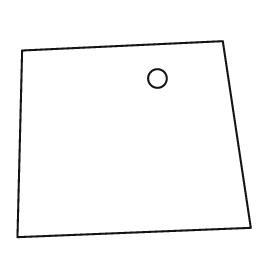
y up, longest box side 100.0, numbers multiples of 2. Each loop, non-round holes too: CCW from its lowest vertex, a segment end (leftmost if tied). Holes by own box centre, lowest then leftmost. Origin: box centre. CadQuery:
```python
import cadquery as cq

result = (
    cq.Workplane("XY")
    .moveTo(-50.0, -42.0)
    .lineTo(50.0, -38.0)
    .lineTo(38.0, 42.0)
    .lineTo(-48.0, 38.0)
    .close()
    .moveTo(10.0, 26.0)
    .circle(4.0)
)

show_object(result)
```